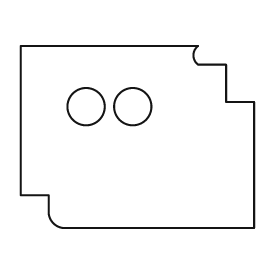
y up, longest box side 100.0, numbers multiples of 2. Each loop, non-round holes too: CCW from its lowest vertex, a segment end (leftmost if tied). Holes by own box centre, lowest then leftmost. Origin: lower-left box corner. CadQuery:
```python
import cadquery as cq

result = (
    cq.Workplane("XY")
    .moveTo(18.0, 0.0)
    .lineTo(100.0, 0.0)
    .lineTo(100.0, 54.0)
    .lineTo(88.0, 54.0)
    .lineTo(88.0, 70.0)
    .lineTo(76.0, 70.0)
    .threePointArc((74.0, 74.0), (76.0, 78.0))
    .lineTo(0.0, 78.0)
    .lineTo(0.0, 14.0)
    .lineTo(12.0, 14.0)
    .lineTo(12.0, 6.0)
    .threePointArc((14.0, 2.0), (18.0, 0.0))
    .close()
    .moveTo(28.0, 52.0)
    .circle(8.0)
    .moveTo(48.0, 52.0)
    .circle(8.0)
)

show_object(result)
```